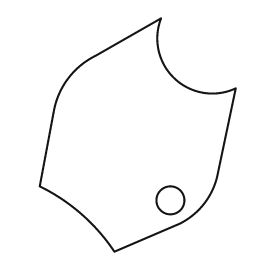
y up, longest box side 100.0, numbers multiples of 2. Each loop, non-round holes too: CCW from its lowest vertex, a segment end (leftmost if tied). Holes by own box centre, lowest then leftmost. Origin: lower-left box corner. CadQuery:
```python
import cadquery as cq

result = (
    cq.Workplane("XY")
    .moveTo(32.0, 0.0)
    .lineTo(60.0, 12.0)
    .threePointArc((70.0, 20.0), (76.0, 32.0))
    .lineTo(84.0, 70.0)
    .threePointArc((58.0, 74.0), (52.0, 100.0))
    .lineTo(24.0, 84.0)
    .threePointArc((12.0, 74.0), (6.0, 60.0))
    .lineTo(0.0, 28.0)
    .threePointArc((18.0, 16.0), (32.0, 0.0))
    .close()
    .moveTo(56.0, 22.0)
    .circle(6.0)
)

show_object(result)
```